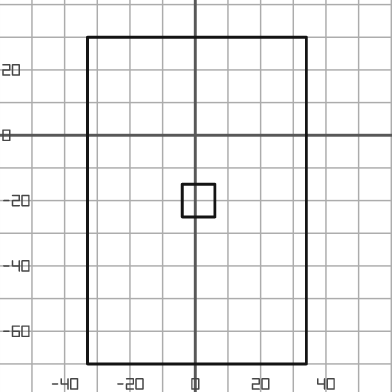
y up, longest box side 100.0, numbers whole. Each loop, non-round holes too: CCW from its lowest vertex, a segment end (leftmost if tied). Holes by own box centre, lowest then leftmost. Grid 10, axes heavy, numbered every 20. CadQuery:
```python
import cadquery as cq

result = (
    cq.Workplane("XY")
    .moveTo(-33.0, -70.0)
    .lineTo(34.0, -70.0)
    .lineTo(34.0, 30.0)
    .lineTo(-33.0, 30.0)
    .close()
    .moveTo(-4.0, -25.0)
    .lineTo(6.0, -25.0)
    .lineTo(6.0, -15.0)
    .lineTo(-4.0, -15.0)
    .close()
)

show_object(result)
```